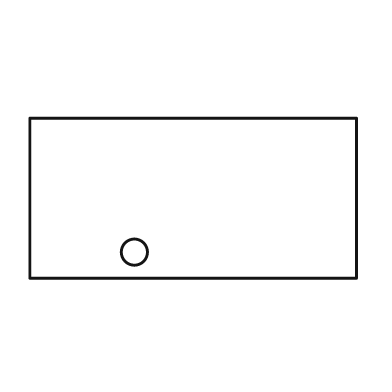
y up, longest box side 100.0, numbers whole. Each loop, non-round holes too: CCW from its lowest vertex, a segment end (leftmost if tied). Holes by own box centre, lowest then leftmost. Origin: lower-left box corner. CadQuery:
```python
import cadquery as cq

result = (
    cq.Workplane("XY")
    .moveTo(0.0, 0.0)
    .lineTo(100.0, 0.0)
    .lineTo(100.0, 49.0)
    .lineTo(0.0, 49.0)
    .close()
    .moveTo(32.0, 8.0)
    .circle(4.0)
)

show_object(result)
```